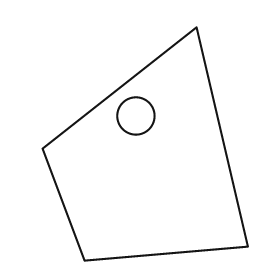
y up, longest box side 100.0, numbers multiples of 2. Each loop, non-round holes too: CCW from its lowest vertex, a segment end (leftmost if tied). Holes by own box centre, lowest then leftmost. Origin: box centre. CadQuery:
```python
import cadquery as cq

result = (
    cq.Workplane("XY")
    .moveTo(-26.0, -50.0)
    .lineTo(44.0, -44.0)
    .lineTo(22.0, 50.0)
    .lineTo(-44.0, -2.0)
    .close()
    .moveTo(-4.0, 12.0)
    .circle(8.0)
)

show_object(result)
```